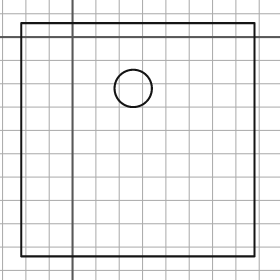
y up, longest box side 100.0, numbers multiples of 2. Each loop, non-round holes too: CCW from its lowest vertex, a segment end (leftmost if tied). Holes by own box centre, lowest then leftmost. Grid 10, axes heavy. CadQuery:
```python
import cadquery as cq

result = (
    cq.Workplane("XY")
    .moveTo(-22.0, -94.0)
    .lineTo(78.0, -94.0)
    .lineTo(78.0, 6.0)
    .lineTo(-22.0, 6.0)
    .close()
    .moveTo(26.0, -22.0)
    .circle(8.0)
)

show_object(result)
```